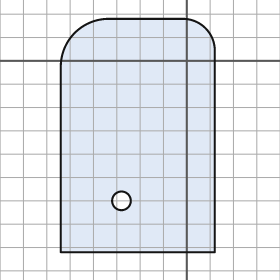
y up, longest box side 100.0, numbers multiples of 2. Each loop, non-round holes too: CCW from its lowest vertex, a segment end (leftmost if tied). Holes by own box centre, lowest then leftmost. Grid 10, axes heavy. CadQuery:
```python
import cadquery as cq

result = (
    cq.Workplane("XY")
    .moveTo(-54.0, -82.0)
    .lineTo(12.0, -82.0)
    .lineTo(12.0, 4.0)
    .threePointArc((8.0, 14.0), (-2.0, 18.0))
    .lineTo(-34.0, 18.0)
    .threePointArc((-48.0, 12.0), (-54.0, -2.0))
    .close()
    .moveTo(-28.0, -60.0)
    .circle(4.0)
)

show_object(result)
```